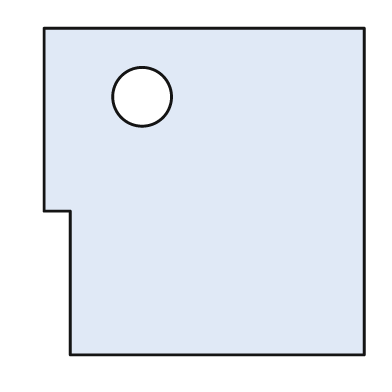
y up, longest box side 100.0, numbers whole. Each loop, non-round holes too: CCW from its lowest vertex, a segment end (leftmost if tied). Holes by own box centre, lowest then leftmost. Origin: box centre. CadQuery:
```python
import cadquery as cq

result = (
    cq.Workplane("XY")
    .moveTo(-41.0, -50.0)
    .lineTo(49.0, -50.0)
    .lineTo(49.0, 50.0)
    .lineTo(-49.0, 50.0)
    .lineTo(-49.0, -6.0)
    .lineTo(-41.0, -6.0)
    .close()
    .moveTo(-19.0, 29.0)
    .circle(9.0)
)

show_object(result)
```